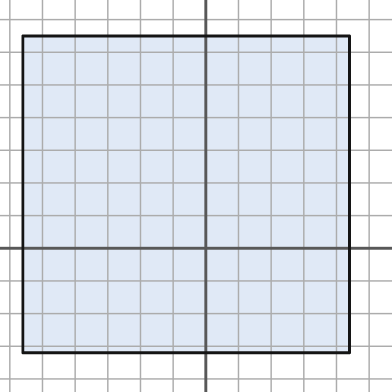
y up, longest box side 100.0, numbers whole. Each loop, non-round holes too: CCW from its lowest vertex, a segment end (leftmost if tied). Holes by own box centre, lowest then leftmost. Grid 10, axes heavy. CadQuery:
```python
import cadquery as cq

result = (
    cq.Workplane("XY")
    .moveTo(-56.0, -32.0)
    .lineTo(44.0, -32.0)
    .lineTo(44.0, 65.0)
    .lineTo(-56.0, 65.0)
    .close()
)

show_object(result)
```